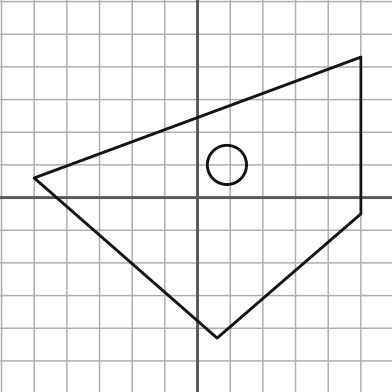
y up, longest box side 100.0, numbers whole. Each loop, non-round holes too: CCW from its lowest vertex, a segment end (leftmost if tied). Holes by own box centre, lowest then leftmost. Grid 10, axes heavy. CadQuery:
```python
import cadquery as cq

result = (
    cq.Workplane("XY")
    .moveTo(6.0, -43.0)
    .lineTo(50.0, -5.0)
    .lineTo(50.0, 43.0)
    .lineTo(-50.0, 6.0)
    .close()
    .moveTo(9.0, 10.0)
    .circle(6.0)
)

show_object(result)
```